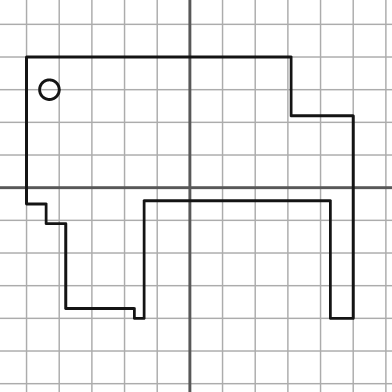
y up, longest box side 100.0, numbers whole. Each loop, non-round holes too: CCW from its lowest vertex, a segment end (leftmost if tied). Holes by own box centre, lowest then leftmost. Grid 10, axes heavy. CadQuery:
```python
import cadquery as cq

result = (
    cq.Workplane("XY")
    .moveTo(-17.0, -40.0)
    .lineTo(-14.0, -40.0)
    .lineTo(-14.0, -4.0)
    .lineTo(43.0, -4.0)
    .lineTo(43.0, -40.0)
    .lineTo(50.0, -40.0)
    .lineTo(50.0, 22.0)
    .lineTo(31.0, 22.0)
    .lineTo(31.0, 40.0)
    .lineTo(-50.0, 40.0)
    .lineTo(-50.0, -5.0)
    .lineTo(-44.0, -5.0)
    .lineTo(-44.0, -11.0)
    .lineTo(-38.0, -11.0)
    .lineTo(-38.0, -37.0)
    .lineTo(-17.0, -37.0)
    .close()
    .moveTo(-43.0, 30.0)
    .circle(3.0)
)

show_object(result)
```